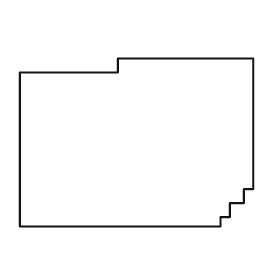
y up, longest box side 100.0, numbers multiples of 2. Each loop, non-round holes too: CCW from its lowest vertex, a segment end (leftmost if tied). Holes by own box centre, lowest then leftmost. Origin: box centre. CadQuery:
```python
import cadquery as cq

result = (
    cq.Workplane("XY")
    .moveTo(-50.0, -36.0)
    .lineTo(36.0, -36.0)
    .lineTo(36.0, -32.0)
    .lineTo(40.0, -32.0)
    .lineTo(40.0, -26.0)
    .lineTo(46.0, -26.0)
    .lineTo(46.0, -20.0)
    .lineTo(50.0, -20.0)
    .lineTo(50.0, 36.0)
    .lineTo(-8.0, 36.0)
    .lineTo(-8.0, 30.0)
    .lineTo(-50.0, 30.0)
    .close()
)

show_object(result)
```